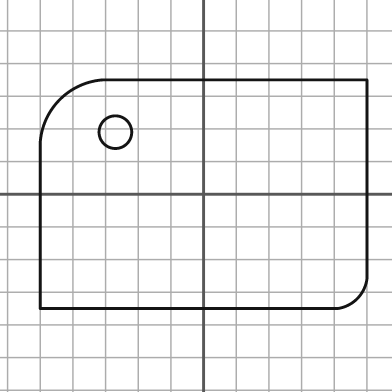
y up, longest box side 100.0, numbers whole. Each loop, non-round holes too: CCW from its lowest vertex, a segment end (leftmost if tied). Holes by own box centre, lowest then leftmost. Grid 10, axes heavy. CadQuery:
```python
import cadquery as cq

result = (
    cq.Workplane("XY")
    .moveTo(-50.0, -35.0)
    .lineTo(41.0, -35.0)
    .threePointArc((47.0, -32.0), (50.0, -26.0))
    .lineTo(50.0, 35.0)
    .lineTo(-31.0, 35.0)
    .threePointArc((-44.0, 29.0), (-50.0, 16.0))
    .close()
    .moveTo(-27.0, 19.0)
    .circle(5.0)
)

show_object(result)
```